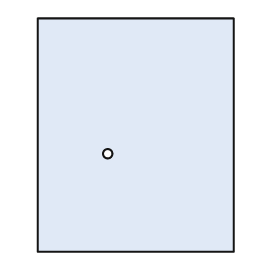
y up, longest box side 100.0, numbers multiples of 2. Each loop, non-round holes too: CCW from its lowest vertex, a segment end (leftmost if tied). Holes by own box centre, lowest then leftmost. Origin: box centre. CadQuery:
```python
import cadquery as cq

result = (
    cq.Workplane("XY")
    .moveTo(-42.0, -50.0)
    .lineTo(42.0, -50.0)
    .lineTo(42.0, 50.0)
    .lineTo(-42.0, 50.0)
    .close()
    .moveTo(-12.0, -8.0)
    .circle(2.0)
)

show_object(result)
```